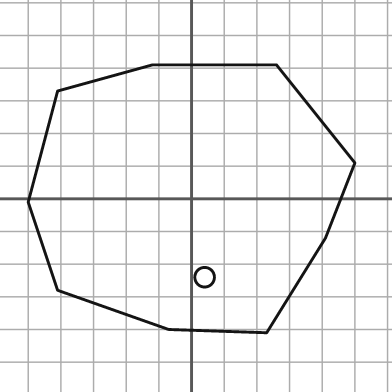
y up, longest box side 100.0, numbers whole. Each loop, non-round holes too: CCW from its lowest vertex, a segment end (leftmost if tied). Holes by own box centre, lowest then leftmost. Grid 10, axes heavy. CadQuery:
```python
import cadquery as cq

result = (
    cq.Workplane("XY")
    .moveTo(23.0, -41.0)
    .lineTo(41.0, -12.0)
    .lineTo(50.0, 11.0)
    .lineTo(26.0, 41.0)
    .lineTo(-12.0, 41.0)
    .lineTo(-41.0, 33.0)
    .lineTo(-50.0, -1.0)
    .lineTo(-41.0, -28.0)
    .lineTo(-7.0, -40.0)
    .close()
    .moveTo(4.0, -24.0)
    .circle(3.0)
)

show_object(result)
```